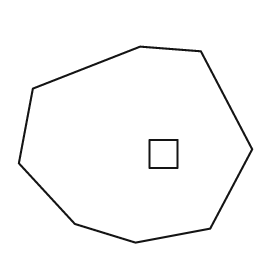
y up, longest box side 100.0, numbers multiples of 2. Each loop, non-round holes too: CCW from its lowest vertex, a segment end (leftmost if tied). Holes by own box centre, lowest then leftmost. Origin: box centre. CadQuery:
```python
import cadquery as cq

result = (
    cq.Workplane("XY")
    .moveTo(0.0, -42.0)
    .lineTo(32.0, -36.0)
    .lineTo(50.0, -2.0)
    .lineTo(28.0, 40.0)
    .lineTo(2.0, 42.0)
    .lineTo(-44.0, 24.0)
    .lineTo(-50.0, -8.0)
    .lineTo(-26.0, -34.0)
    .close()
    .moveTo(6.0, -10.0)
    .lineTo(18.0, -10.0)
    .lineTo(18.0, 2.0)
    .lineTo(6.0, 2.0)
    .close()
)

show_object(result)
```